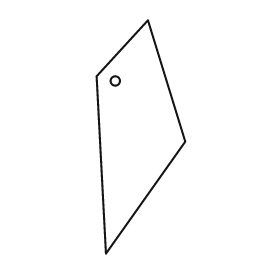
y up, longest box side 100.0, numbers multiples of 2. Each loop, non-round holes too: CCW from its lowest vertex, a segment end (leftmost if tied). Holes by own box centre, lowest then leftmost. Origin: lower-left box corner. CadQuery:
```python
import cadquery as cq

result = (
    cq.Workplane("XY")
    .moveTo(4.0, 0.0)
    .lineTo(38.0, 48.0)
    .lineTo(22.0, 100.0)
    .lineTo(0.0, 76.0)
    .close()
    .moveTo(8.0, 74.0)
    .circle(2.0)
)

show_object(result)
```